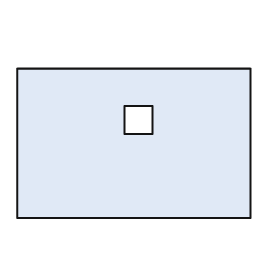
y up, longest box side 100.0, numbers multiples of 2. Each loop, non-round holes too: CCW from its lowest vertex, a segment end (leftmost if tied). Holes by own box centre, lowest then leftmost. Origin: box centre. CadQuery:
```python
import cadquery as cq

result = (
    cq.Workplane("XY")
    .moveTo(-50.0, -32.0)
    .lineTo(50.0, -32.0)
    .lineTo(50.0, 32.0)
    .lineTo(-50.0, 32.0)
    .close()
    .moveTo(-4.0, 4.0)
    .lineTo(8.0, 4.0)
    .lineTo(8.0, 16.0)
    .lineTo(-4.0, 16.0)
    .close()
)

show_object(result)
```